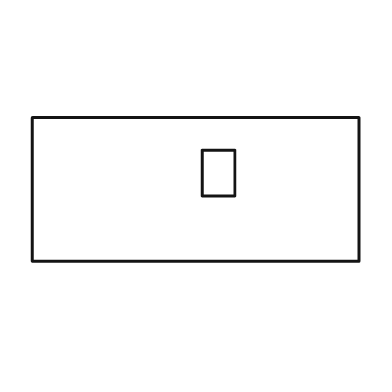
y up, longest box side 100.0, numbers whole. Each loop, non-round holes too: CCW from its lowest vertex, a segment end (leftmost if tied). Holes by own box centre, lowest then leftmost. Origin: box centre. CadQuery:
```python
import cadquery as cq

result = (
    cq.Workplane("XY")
    .moveTo(-50.0, -22.0)
    .lineTo(50.0, -22.0)
    .lineTo(50.0, 22.0)
    .lineTo(-50.0, 22.0)
    .close()
    .moveTo(2.0, -2.0)
    .lineTo(12.0, -2.0)
    .lineTo(12.0, 12.0)
    .lineTo(2.0, 12.0)
    .close()
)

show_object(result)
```